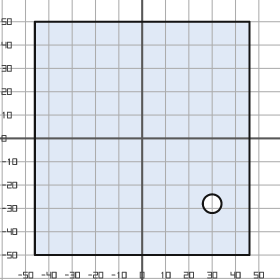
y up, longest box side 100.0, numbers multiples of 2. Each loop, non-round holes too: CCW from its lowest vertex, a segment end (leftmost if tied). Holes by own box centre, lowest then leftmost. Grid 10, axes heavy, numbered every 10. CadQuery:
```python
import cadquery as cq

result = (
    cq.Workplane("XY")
    .moveTo(-46.0, -50.0)
    .lineTo(46.0, -50.0)
    .lineTo(46.0, 50.0)
    .lineTo(-46.0, 50.0)
    .close()
    .moveTo(30.0, -28.0)
    .circle(4.0)
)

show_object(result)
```